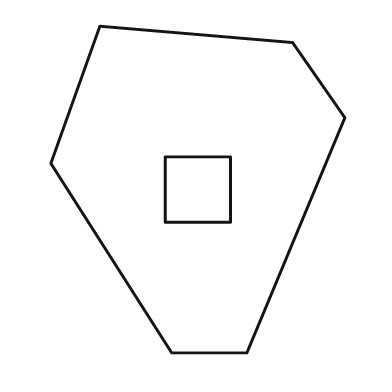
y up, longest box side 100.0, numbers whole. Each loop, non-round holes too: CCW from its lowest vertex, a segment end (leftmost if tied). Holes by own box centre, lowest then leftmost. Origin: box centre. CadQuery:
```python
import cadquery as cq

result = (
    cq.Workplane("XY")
    .moveTo(-8.0, -50.0)
    .lineTo(15.0, -50.0)
    .lineTo(45.0, 22.0)
    .lineTo(29.0, 45.0)
    .lineTo(-30.0, 50.0)
    .lineTo(-45.0, 8.0)
    .close()
    .moveTo(-10.0, -10.0)
    .lineTo(10.0, -10.0)
    .lineTo(10.0, 10.0)
    .lineTo(-10.0, 10.0)
    .close()
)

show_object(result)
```